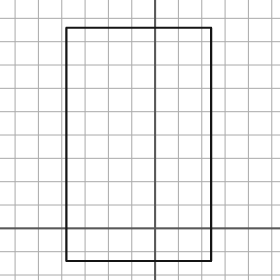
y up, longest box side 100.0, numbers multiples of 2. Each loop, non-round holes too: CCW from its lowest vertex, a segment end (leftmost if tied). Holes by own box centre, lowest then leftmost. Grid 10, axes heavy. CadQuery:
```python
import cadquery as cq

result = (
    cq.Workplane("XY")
    .moveTo(-38.0, -14.0)
    .lineTo(24.0, -14.0)
    .lineTo(24.0, 86.0)
    .lineTo(-38.0, 86.0)
    .close()
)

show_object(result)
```